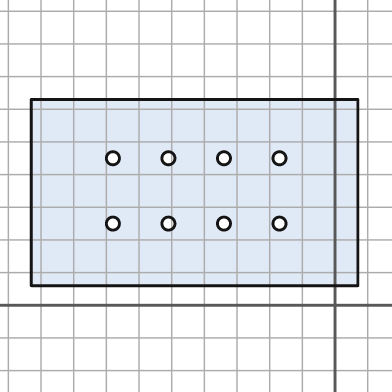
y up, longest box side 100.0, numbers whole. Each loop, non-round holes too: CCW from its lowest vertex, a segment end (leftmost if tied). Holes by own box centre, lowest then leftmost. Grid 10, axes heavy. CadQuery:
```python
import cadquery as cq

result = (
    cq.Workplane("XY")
    .moveTo(-93.0, 6.0)
    .lineTo(7.0, 6.0)
    .lineTo(7.0, 63.0)
    .lineTo(-93.0, 63.0)
    .close()
    .moveTo(-68.0, 25.0)
    .circle(2.0)
    .moveTo(-51.0, 25.0)
    .circle(2.0)
    .moveTo(-34.0, 25.0)
    .circle(2.0)
    .moveTo(-17.0, 25.0)
    .circle(2.0)
    .moveTo(-68.0, 45.0)
    .circle(2.0)
    .moveTo(-51.0, 45.0)
    .circle(2.0)
    .moveTo(-34.0, 45.0)
    .circle(2.0)
    .moveTo(-17.0, 45.0)
    .circle(2.0)
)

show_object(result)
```